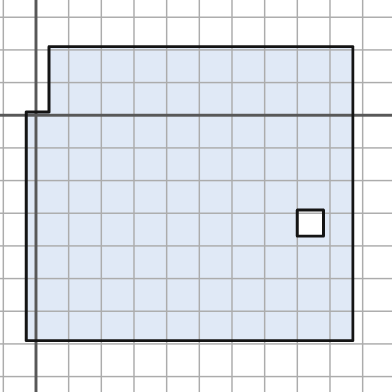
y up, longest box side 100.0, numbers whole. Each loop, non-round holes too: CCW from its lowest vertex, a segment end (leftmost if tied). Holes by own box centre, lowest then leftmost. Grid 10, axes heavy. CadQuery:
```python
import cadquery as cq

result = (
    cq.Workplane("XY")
    .moveTo(-3.0, -69.0)
    .lineTo(97.0, -69.0)
    .lineTo(97.0, 21.0)
    .lineTo(4.0, 21.0)
    .lineTo(4.0, 1.0)
    .lineTo(-3.0, 1.0)
    .close()
    .moveTo(80.0, -37.0)
    .lineTo(88.0, -37.0)
    .lineTo(88.0, -29.0)
    .lineTo(80.0, -29.0)
    .close()
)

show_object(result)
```